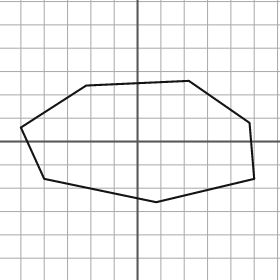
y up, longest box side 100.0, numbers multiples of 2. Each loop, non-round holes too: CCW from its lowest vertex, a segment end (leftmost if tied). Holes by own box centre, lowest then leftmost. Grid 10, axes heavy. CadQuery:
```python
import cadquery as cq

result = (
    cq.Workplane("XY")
    .moveTo(8.0, -26.0)
    .lineTo(50.0, -16.0)
    .lineTo(48.0, 8.0)
    .lineTo(22.0, 26.0)
    .lineTo(-22.0, 24.0)
    .lineTo(-50.0, 6.0)
    .lineTo(-40.0, -16.0)
    .close()
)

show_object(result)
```